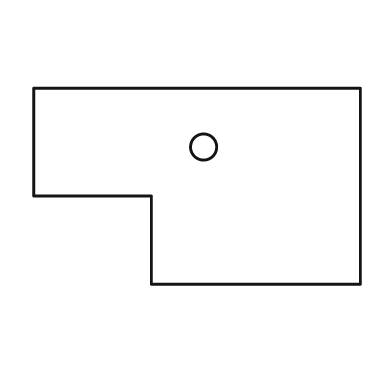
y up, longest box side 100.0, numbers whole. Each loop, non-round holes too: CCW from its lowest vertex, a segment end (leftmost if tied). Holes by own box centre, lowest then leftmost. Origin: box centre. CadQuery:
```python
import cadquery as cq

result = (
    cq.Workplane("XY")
    .moveTo(-14.0, -30.0)
    .lineTo(50.0, -30.0)
    .lineTo(50.0, 30.0)
    .lineTo(-50.0, 30.0)
    .lineTo(-50.0, -3.0)
    .lineTo(-14.0, -3.0)
    .close()
    .moveTo(2.0, 12.0)
    .circle(4.0)
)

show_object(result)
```